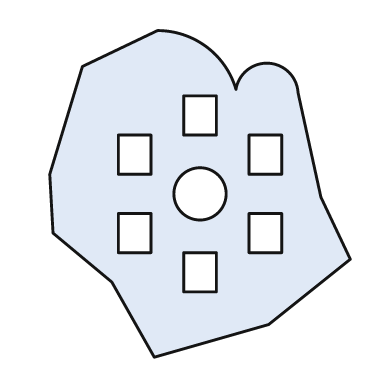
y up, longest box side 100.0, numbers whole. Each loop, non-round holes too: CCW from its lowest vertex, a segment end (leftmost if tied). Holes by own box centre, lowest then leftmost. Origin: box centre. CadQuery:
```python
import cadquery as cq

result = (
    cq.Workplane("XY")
    .moveTo(-14.0, -50.0)
    .lineTo(21.0, -40.0)
    .lineTo(46.0, -20.0)
    .lineTo(37.0, -1.0)
    .lineTo(30.0, 31.0)
    .threePointArc((21.0, 40.0), (11.0, 32.0))
    .threePointArc((2.0, 45.0), (-13.0, 50.0))
    .lineTo(-36.0, 39.0)
    .lineTo(-46.0, 6.0)
    .lineTo(-45.0, -12.0)
    .lineTo(-27.0, -27.0)
    .close()
    .moveTo(-5.0, -30.0)
    .lineTo(5.0, -30.0)
    .lineTo(5.0, -18.0)
    .lineTo(-5.0, -18.0)
    .close()
    .moveTo(-25.0, -18.0)
    .lineTo(-15.0, -18.0)
    .lineTo(-15.0, -6.0)
    .lineTo(-25.0, -6.0)
    .close()
    .moveTo(15.0, -18.0)
    .lineTo(25.0, -18.0)
    .lineTo(25.0, -6.0)
    .lineTo(15.0, -6.0)
    .close()
    .moveTo(0.0, 0.0)
    .circle(8.0)
    .moveTo(-25.0, 6.0)
    .lineTo(-15.0, 6.0)
    .lineTo(-15.0, 18.0)
    .lineTo(-25.0, 18.0)
    .close()
    .moveTo(15.0, 6.0)
    .lineTo(25.0, 6.0)
    .lineTo(25.0, 18.0)
    .lineTo(15.0, 18.0)
    .close()
    .moveTo(-5.0, 18.0)
    .lineTo(5.0, 18.0)
    .lineTo(5.0, 30.0)
    .lineTo(-5.0, 30.0)
    .close()
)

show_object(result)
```